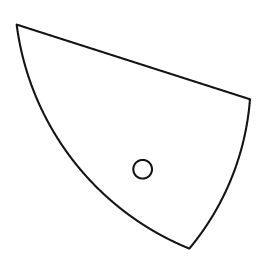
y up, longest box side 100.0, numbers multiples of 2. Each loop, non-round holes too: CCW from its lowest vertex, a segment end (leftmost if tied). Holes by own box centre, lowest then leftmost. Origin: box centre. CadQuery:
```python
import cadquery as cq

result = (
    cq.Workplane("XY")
    .moveTo(24.0, -48.0)
    .threePointArc((42.0, -18.0), (50.0, 16.0))
    .lineTo(-50.0, 48.0)
    .threePointArc((-26.0, -10.0), (24.0, -48.0))
    .close()
    .moveTo(4.0, -14.0)
    .circle(4.0)
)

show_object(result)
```